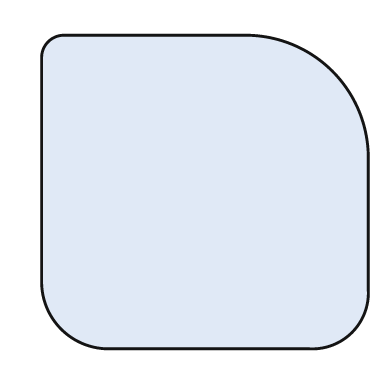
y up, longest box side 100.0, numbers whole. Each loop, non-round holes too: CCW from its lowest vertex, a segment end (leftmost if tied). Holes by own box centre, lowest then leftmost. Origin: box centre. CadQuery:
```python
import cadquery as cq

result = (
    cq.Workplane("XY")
    .moveTo(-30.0, -48.0)
    .lineTo(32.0, -48.0)
    .threePointArc((45.0, -43.0), (50.0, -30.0))
    .lineTo(50.0, 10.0)
    .threePointArc((39.0, 37.0), (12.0, 48.0))
    .lineTo(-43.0, 48.0)
    .threePointArc((-48.0, 46.0), (-50.0, 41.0))
    .lineTo(-50.0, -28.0)
    .threePointArc((-44.0, -42.0), (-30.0, -48.0))
    .close()
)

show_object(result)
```